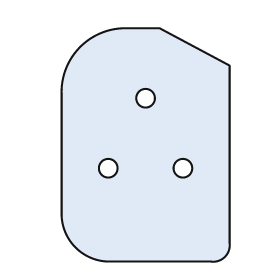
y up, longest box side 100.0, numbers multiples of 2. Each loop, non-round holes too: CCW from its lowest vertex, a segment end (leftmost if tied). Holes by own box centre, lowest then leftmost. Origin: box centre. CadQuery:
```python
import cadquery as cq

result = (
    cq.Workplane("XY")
    .moveTo(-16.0, -50.0)
    .lineTo(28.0, -50.0)
    .threePointArc((34.0, -48.0), (36.0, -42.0))
    .lineTo(36.0, 34.0)
    .lineTo(6.0, 50.0)
    .lineTo(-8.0, 50.0)
    .threePointArc((-28.0, 42.0), (-36.0, 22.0))
    .lineTo(-36.0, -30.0)
    .threePointArc((-30.0, -44.0), (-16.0, -50.0))
    .close()
    .moveTo(-16.0, -10.0)
    .circle(4.0)
    .moveTo(16.0, -10.0)
    .circle(4.0)
    .moveTo(0.0, 20.0)
    .circle(4.0)
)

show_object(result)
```